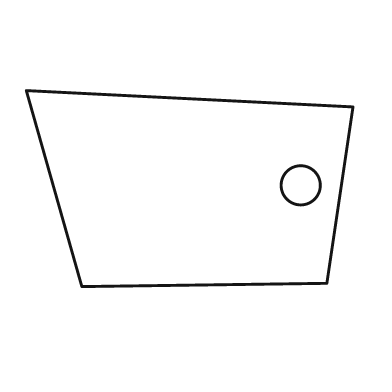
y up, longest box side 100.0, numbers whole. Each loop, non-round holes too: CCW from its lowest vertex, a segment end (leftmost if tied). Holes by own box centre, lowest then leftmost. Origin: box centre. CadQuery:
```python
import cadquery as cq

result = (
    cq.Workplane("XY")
    .moveTo(-33.0, -30.0)
    .lineTo(42.0, -29.0)
    .lineTo(50.0, 25.0)
    .lineTo(-50.0, 30.0)
    .close()
    .moveTo(34.0, 1.0)
    .circle(6.0)
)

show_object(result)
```